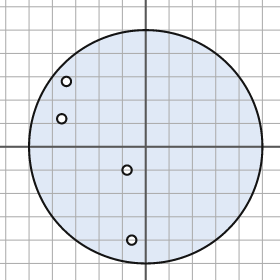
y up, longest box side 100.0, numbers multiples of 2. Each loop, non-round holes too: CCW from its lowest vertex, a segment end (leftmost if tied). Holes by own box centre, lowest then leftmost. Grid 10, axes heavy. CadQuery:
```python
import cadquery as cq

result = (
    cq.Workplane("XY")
    .moveTo(0.0, 0.0)
    .circle(50.0)
    .moveTo(-6.0, -40.0)
    .circle(2.0)
    .moveTo(-8.0, -10.0)
    .circle(2.0)
    .moveTo(-36.0, 12.0)
    .circle(2.0)
    .moveTo(-34.0, 28.0)
    .circle(2.0)
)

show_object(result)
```